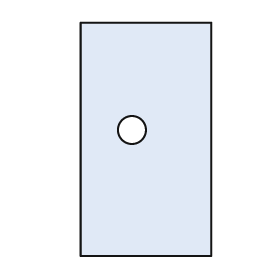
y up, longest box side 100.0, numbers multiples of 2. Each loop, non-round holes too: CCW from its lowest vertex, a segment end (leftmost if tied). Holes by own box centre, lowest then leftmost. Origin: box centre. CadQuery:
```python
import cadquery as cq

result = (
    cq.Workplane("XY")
    .moveTo(-28.0, -50.0)
    .lineTo(28.0, -50.0)
    .lineTo(28.0, 50.0)
    .lineTo(-28.0, 50.0)
    .close()
    .moveTo(-6.0, 4.0)
    .circle(6.0)
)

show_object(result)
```